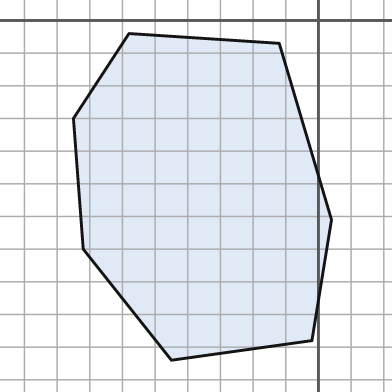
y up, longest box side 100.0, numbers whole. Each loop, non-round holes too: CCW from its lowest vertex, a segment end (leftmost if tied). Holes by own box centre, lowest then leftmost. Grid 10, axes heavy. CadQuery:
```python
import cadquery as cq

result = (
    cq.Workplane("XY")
    .moveTo(-45.0, -104.0)
    .lineTo(-2.0, -98.0)
    .lineTo(4.0, -61.0)
    .lineTo(-12.0, -7.0)
    .lineTo(-58.0, -4.0)
    .lineTo(-75.0, -30.0)
    .lineTo(-72.0, -70.0)
    .close()
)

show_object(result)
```